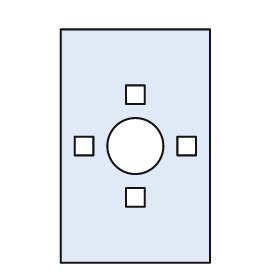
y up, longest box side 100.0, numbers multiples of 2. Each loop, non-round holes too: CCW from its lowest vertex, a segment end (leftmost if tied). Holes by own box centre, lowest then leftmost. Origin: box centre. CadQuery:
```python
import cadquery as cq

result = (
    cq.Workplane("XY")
    .moveTo(-32.0, -50.0)
    .lineTo(32.0, -50.0)
    .lineTo(32.0, 50.0)
    .lineTo(-32.0, 50.0)
    .close()
    .moveTo(-4.0, -26.0)
    .lineTo(4.0, -26.0)
    .lineTo(4.0, -18.0)
    .lineTo(-4.0, -18.0)
    .close()
    .moveTo(-26.0, -4.0)
    .lineTo(-18.0, -4.0)
    .lineTo(-18.0, 4.0)
    .lineTo(-26.0, 4.0)
    .close()
    .moveTo(0.0, 0.0)
    .circle(12.0)
    .moveTo(18.0, -4.0)
    .lineTo(26.0, -4.0)
    .lineTo(26.0, 4.0)
    .lineTo(18.0, 4.0)
    .close()
    .moveTo(-4.0, 18.0)
    .lineTo(4.0, 18.0)
    .lineTo(4.0, 26.0)
    .lineTo(-4.0, 26.0)
    .close()
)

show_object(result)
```